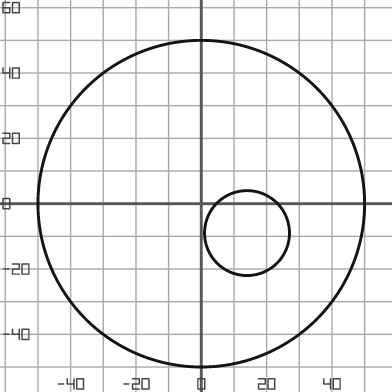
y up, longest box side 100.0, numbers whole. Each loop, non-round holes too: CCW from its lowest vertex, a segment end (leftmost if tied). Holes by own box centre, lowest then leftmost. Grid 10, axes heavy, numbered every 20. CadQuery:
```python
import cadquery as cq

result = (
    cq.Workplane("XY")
    .moveTo(0.0, 0.0)
    .circle(50.0)
    .moveTo(14.0, -9.0)
    .circle(13.0)
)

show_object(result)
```